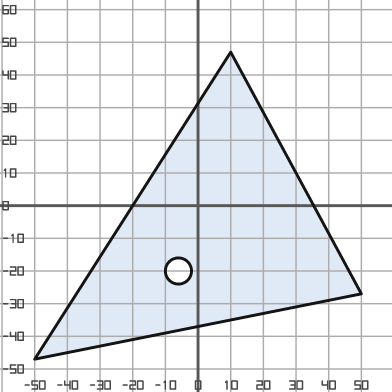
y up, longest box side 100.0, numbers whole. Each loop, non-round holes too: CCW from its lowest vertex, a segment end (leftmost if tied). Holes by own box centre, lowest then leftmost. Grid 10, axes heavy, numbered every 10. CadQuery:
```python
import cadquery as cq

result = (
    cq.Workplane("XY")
    .moveTo(-50.0, -47.0)
    .lineTo(50.0, -27.0)
    .lineTo(10.0, 47.0)
    .close()
    .moveTo(-6.0, -20.0)
    .circle(4.0)
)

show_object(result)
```